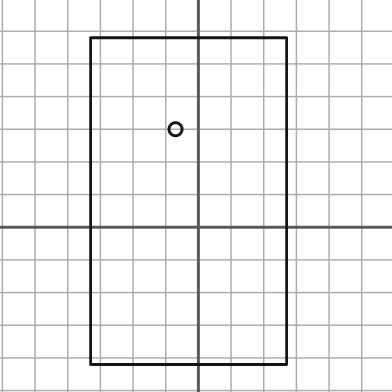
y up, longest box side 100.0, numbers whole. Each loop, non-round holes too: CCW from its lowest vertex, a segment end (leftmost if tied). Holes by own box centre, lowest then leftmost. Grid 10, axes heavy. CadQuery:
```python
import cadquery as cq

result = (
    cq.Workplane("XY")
    .moveTo(-33.0, -42.0)
    .lineTo(27.0, -42.0)
    .lineTo(27.0, 58.0)
    .lineTo(-33.0, 58.0)
    .close()
    .moveTo(-7.0, 30.0)
    .circle(2.0)
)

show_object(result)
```